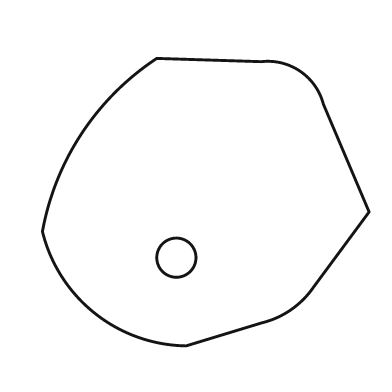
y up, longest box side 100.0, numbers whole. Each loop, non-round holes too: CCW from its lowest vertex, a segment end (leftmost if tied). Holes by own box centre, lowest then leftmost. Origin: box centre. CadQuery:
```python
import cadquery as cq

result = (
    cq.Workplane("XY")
    .moveTo(-6.0, -44.0)
    .lineTo(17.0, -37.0)
    .threePointArc((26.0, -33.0), (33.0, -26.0))
    .lineTo(50.0, -3.0)
    .lineTo(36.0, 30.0)
    .threePointArc((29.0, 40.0), (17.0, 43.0))
    .lineTo(-15.0, 44.0)
    .threePointArc((-38.0, 21.0), (-50.0, -9.0))
    .threePointArc((-34.0, -34.0), (-6.0, -44.0))
    .close()
    .moveTo(-9.0, -17.0)
    .circle(6.0)
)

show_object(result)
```